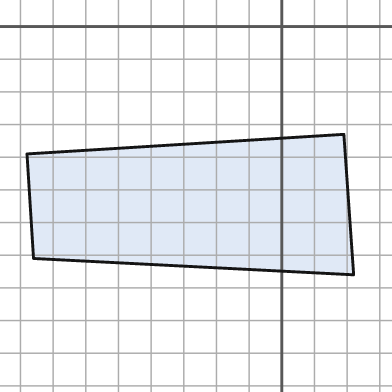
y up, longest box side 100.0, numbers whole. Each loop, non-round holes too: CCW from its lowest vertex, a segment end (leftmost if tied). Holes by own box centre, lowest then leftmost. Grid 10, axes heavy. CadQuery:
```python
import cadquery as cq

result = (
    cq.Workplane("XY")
    .moveTo(22.0, -76.0)
    .lineTo(19.0, -33.0)
    .lineTo(-78.0, -39.0)
    .lineTo(-76.0, -71.0)
    .close()
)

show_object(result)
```